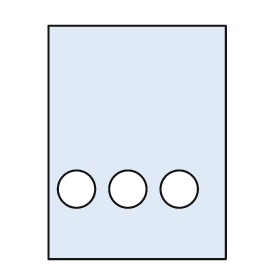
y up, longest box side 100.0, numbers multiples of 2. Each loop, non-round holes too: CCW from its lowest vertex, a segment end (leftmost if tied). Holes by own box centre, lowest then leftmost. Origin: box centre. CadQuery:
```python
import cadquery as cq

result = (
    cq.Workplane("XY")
    .moveTo(-38.0, -50.0)
    .lineTo(38.0, -50.0)
    .lineTo(38.0, 50.0)
    .lineTo(-38.0, 50.0)
    .close()
    .moveTo(-26.0, -20.0)
    .circle(8.0)
    .moveTo(-4.0, -20.0)
    .circle(8.0)
    .moveTo(18.0, -20.0)
    .circle(8.0)
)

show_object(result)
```